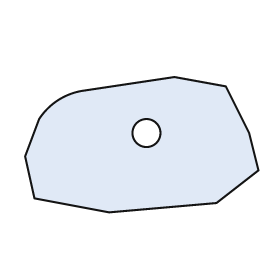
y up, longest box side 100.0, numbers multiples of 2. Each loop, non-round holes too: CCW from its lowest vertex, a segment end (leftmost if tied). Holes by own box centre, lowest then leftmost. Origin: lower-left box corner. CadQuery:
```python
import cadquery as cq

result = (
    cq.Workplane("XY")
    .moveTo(36.0, 0.0)
    .lineTo(82.0, 4.0)
    .lineTo(100.0, 18.0)
    .lineTo(96.0, 34.0)
    .lineTo(86.0, 54.0)
    .lineTo(64.0, 58.0)
    .lineTo(24.0, 52.0)
    .threePointArc((14.0, 48.0), (6.0, 40.0))
    .lineTo(0.0, 24.0)
    .lineTo(4.0, 6.0)
    .close()
    .moveTo(52.0, 34.0)
    .circle(6.0)
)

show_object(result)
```